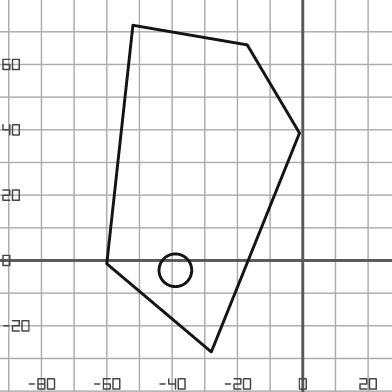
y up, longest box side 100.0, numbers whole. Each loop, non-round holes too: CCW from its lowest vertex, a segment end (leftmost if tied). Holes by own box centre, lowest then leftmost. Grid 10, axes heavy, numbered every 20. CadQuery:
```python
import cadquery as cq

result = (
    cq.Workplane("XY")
    .moveTo(-28.0, -28.0)
    .lineTo(-1.0, 39.0)
    .lineTo(-17.0, 66.0)
    .lineTo(-52.0, 72.0)
    .lineTo(-60.0, -1.0)
    .close()
    .moveTo(-39.0, -3.0)
    .circle(5.0)
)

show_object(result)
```